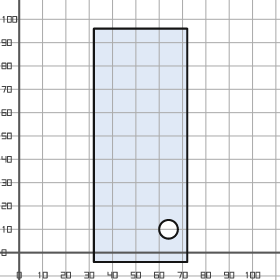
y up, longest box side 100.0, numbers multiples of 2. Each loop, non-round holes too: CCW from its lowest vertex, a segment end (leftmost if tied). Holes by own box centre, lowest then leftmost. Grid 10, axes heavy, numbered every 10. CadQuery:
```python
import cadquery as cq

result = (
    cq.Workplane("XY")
    .moveTo(32.0, -4.0)
    .lineTo(72.0, -4.0)
    .lineTo(72.0, 96.0)
    .lineTo(32.0, 96.0)
    .close()
    .moveTo(64.0, 10.0)
    .circle(4.0)
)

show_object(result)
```